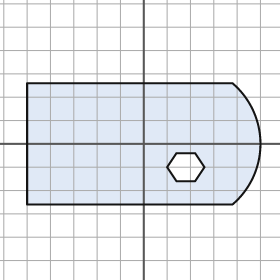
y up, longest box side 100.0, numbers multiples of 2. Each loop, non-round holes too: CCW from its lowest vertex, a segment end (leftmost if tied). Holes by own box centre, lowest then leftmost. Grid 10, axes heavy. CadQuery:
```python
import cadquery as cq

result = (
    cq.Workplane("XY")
    .moveTo(-50.0, -26.0)
    .lineTo(38.0, -26.0)
    .threePointArc((50.0, 0.0), (38.0, 26.0))
    .lineTo(-50.0, 26.0)
    .close()
    .moveTo(14.0, -16.0)
    .lineTo(22.0, -16.0)
    .lineTo(26.0, -10.0)
    .lineTo(22.0, -4.0)
    .lineTo(14.0, -4.0)
    .lineTo(10.0, -10.0)
    .close()
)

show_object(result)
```